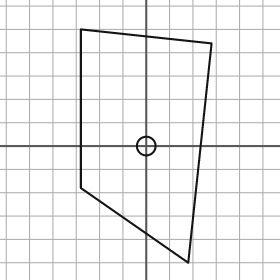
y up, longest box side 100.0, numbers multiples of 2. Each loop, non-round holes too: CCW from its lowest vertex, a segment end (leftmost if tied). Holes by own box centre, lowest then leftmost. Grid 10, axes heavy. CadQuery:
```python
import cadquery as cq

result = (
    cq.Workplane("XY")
    .moveTo(18.0, -50.0)
    .lineTo(28.0, 44.0)
    .lineTo(-28.0, 50.0)
    .lineTo(-28.0, -18.0)
    .close()
    .moveTo(0.0, 0.0)
    .circle(4.0)
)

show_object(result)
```